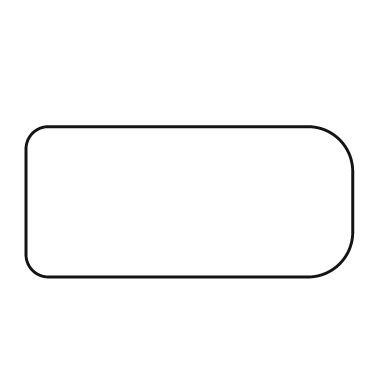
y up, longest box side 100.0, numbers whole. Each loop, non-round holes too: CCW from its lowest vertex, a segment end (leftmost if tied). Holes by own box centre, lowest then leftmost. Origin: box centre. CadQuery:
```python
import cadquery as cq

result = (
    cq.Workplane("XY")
    .moveTo(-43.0, -23.0)
    .lineTo(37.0, -23.0)
    .threePointArc((46.0, -19.0), (50.0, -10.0))
    .lineTo(50.0, 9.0)
    .threePointArc((46.0, 19.0), (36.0, 23.0))
    .lineTo(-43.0, 23.0)
    .threePointArc((-48.0, 21.0), (-50.0, 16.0))
    .lineTo(-50.0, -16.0)
    .threePointArc((-48.0, -21.0), (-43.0, -23.0))
    .close()
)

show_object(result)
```